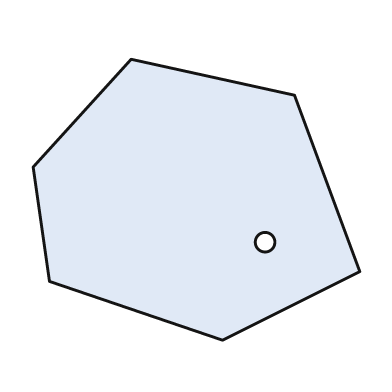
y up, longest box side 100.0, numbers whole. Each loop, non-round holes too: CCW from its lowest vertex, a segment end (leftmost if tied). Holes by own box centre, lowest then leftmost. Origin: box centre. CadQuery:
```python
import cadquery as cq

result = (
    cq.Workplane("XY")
    .moveTo(8.0, -43.0)
    .lineTo(50.0, -22.0)
    .lineTo(30.0, 32.0)
    .lineTo(-20.0, 43.0)
    .lineTo(-50.0, 10.0)
    .lineTo(-45.0, -25.0)
    .close()
    .moveTo(21.0, -13.0)
    .circle(3.0)
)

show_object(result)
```